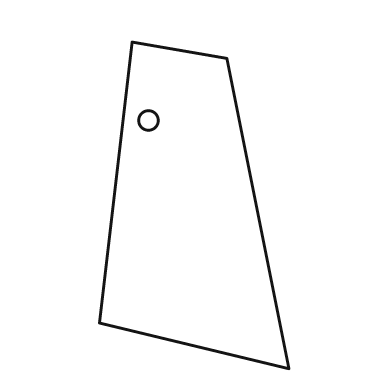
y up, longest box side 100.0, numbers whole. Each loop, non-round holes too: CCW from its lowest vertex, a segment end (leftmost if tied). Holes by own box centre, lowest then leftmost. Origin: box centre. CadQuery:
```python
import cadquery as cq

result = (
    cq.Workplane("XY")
    .moveTo(29.0, -50.0)
    .lineTo(10.0, 45.0)
    .lineTo(-19.0, 50.0)
    .lineTo(-29.0, -36.0)
    .close()
    .moveTo(-14.0, 26.0)
    .circle(3.0)
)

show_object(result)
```